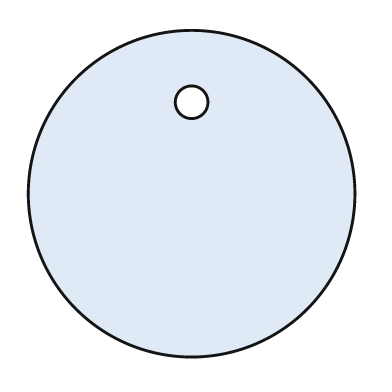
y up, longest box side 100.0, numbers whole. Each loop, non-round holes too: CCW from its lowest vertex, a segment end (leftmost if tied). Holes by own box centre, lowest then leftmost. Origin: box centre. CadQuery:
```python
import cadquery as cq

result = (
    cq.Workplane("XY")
    .moveTo(0.0, 0.0)
    .circle(50.0)
    .moveTo(0.0, 28.0)
    .circle(5.0)
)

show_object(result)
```